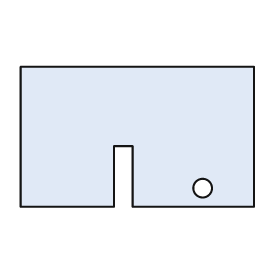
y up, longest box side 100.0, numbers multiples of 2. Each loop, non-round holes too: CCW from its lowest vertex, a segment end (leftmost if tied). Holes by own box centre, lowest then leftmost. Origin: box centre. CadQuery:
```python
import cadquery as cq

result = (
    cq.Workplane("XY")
    .moveTo(-50.0, -30.0)
    .lineTo(-10.0, -30.0)
    .lineTo(-10.0, -4.0)
    .lineTo(-2.0, -4.0)
    .lineTo(-2.0, -30.0)
    .lineTo(50.0, -30.0)
    .lineTo(50.0, 30.0)
    .lineTo(-50.0, 30.0)
    .close()
    .moveTo(28.0, -22.0)
    .circle(4.0)
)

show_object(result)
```